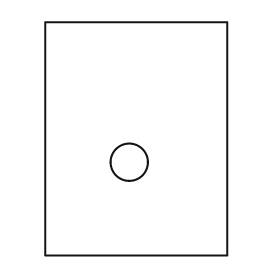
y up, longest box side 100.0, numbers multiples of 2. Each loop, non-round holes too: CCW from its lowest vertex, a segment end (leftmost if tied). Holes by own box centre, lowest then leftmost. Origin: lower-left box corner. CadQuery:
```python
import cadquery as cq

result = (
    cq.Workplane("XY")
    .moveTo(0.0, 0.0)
    .lineTo(78.0, 0.0)
    .lineTo(78.0, 100.0)
    .lineTo(0.0, 100.0)
    .close()
    .moveTo(36.0, 40.0)
    .circle(8.0)
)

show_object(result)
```